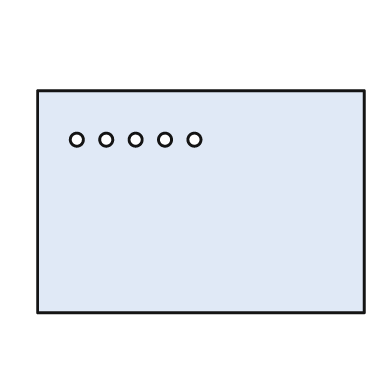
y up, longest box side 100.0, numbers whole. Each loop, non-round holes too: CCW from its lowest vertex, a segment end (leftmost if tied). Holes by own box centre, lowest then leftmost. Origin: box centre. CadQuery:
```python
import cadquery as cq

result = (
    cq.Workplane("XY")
    .moveTo(-50.0, -34.0)
    .lineTo(50.0, -34.0)
    .lineTo(50.0, 34.0)
    .lineTo(-50.0, 34.0)
    .close()
    .moveTo(-38.0, 19.0)
    .circle(2.0)
    .moveTo(-29.0, 19.0)
    .circle(2.0)
    .moveTo(-20.0, 19.0)
    .circle(2.0)
    .moveTo(-11.0, 19.0)
    .circle(2.0)
    .moveTo(-2.0, 19.0)
    .circle(2.0)
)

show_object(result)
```